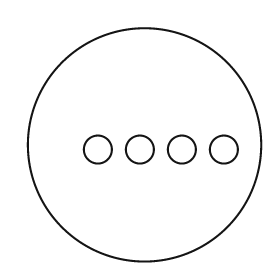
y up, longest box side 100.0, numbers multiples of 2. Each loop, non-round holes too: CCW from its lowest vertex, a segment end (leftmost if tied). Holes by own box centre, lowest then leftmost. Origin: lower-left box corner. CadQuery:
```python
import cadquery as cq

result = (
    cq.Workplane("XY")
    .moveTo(50.0, 50.0)
    .circle(50.0)
    .moveTo(30.0, 48.0)
    .circle(6.0)
    .moveTo(48.0, 48.0)
    .circle(6.0)
    .moveTo(66.0, 48.0)
    .circle(6.0)
    .moveTo(84.0, 48.0)
    .circle(6.0)
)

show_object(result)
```